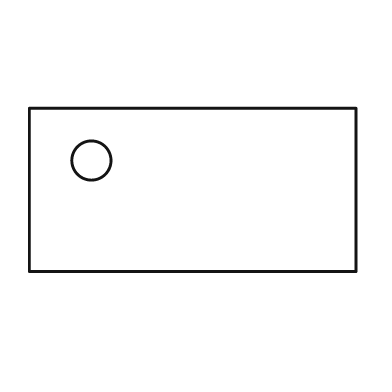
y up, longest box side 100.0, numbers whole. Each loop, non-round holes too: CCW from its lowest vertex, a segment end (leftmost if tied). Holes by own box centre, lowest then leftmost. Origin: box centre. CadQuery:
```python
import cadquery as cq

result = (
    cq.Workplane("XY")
    .moveTo(-50.0, -25.0)
    .lineTo(50.0, -25.0)
    .lineTo(50.0, 25.0)
    .lineTo(-50.0, 25.0)
    .close()
    .moveTo(-31.0, 9.0)
    .circle(6.0)
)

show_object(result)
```